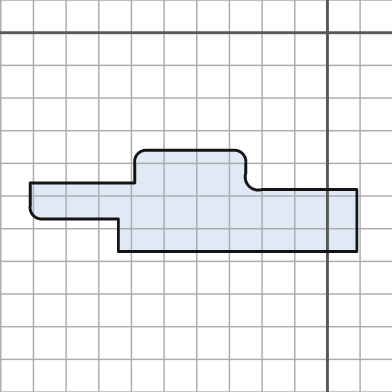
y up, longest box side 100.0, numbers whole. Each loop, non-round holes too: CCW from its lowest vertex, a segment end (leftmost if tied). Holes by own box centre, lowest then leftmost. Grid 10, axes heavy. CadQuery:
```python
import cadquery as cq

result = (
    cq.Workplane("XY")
    .moveTo(-64.0, -67.0)
    .lineTo(9.0, -67.0)
    .lineTo(9.0, -48.0)
    .lineTo(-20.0, -48.0)
    .threePointArc((-24.0, -47.0), (-25.0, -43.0))
    .lineTo(-25.0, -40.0)
    .threePointArc((-26.0, -37.0), (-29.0, -36.0))
    .lineTo(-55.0, -36.0)
    .threePointArc((-58.0, -37.0), (-59.0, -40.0))
    .lineTo(-59.0, -46.0)
    .lineTo(-91.0, -46.0)
    .lineTo(-91.0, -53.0)
    .threePointArc((-90.0, -56.0), (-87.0, -57.0))
    .lineTo(-64.0, -57.0)
    .close()
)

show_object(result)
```